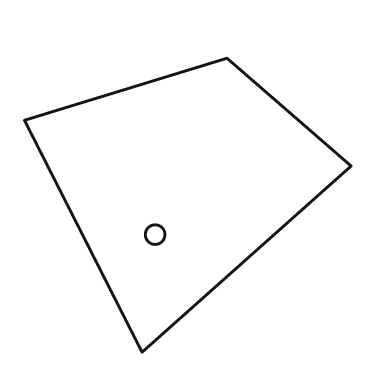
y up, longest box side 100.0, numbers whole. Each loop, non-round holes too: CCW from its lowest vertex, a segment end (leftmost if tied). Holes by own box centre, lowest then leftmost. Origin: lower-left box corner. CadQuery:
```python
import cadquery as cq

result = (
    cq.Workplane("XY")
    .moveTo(36.0, 0.0)
    .lineTo(100.0, 57.0)
    .lineTo(62.0, 90.0)
    .lineTo(0.0, 71.0)
    .close()
    .moveTo(40.0, 36.0)
    .circle(3.0)
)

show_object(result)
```